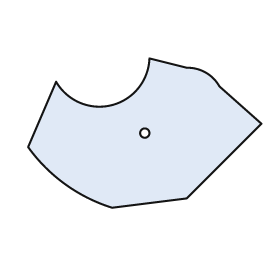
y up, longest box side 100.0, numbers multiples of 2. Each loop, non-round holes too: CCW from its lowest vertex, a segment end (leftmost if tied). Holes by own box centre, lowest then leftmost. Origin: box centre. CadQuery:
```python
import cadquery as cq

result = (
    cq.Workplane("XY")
    .moveTo(-14.0, -32.0)
    .lineTo(18.0, -28.0)
    .lineTo(50.0, 4.0)
    .lineTo(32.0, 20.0)
    .threePointArc((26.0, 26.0), (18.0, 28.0))
    .lineTo(2.0, 32.0)
    .threePointArc((-14.0, 12.0), (-38.0, 22.0))
    .lineTo(-50.0, -6.0)
    .threePointArc((-34.0, -22.0), (-14.0, -32.0))
    .close()
    .moveTo(0.0, 0.0)
    .circle(2.0)
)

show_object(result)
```